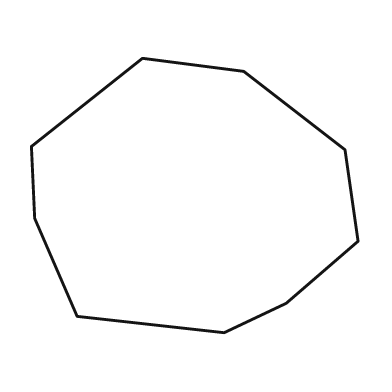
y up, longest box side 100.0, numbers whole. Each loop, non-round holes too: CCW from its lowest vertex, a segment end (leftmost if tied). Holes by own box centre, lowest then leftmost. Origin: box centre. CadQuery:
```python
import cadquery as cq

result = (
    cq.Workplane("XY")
    .moveTo(9.0, -42.0)
    .lineTo(28.0, -33.0)
    .lineTo(50.0, -14.0)
    .lineTo(46.0, 14.0)
    .lineTo(15.0, 38.0)
    .lineTo(-16.0, 42.0)
    .lineTo(-50.0, 15.0)
    .lineTo(-49.0, -7.0)
    .lineTo(-36.0, -37.0)
    .close()
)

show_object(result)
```